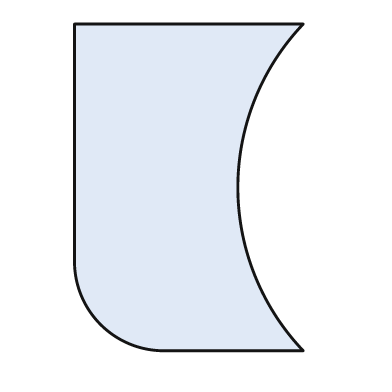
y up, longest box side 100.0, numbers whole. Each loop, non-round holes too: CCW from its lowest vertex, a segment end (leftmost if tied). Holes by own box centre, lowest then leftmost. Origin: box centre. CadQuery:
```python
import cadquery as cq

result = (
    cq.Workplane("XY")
    .moveTo(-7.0, -50.0)
    .lineTo(35.0, -50.0)
    .threePointArc((15.0, 0.0), (35.0, 50.0))
    .lineTo(-35.0, 50.0)
    .lineTo(-35.0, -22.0)
    .threePointArc((-27.0, -42.0), (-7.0, -50.0))
    .close()
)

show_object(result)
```